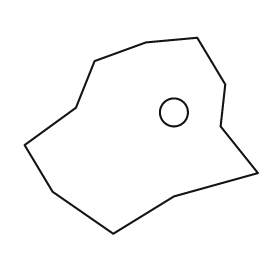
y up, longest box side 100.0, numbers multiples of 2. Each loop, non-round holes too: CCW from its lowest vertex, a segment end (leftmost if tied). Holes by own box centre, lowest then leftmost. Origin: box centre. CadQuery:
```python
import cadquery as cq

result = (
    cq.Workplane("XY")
    .moveTo(-12.0, -42.0)
    .lineTo(14.0, -26.0)
    .lineTo(50.0, -16.0)
    .lineTo(34.0, 4.0)
    .lineTo(36.0, 22.0)
    .lineTo(24.0, 42.0)
    .lineTo(2.0, 40.0)
    .lineTo(-20.0, 32.0)
    .lineTo(-28.0, 12.0)
    .lineTo(-50.0, -4.0)
    .lineTo(-38.0, -24.0)
    .close()
    .moveTo(14.0, 10.0)
    .circle(6.0)
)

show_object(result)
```